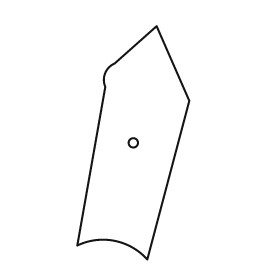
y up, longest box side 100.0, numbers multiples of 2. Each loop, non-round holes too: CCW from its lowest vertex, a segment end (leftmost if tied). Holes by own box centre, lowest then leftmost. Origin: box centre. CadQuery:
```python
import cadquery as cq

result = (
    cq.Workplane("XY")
    .moveTo(6.0, -50.0)
    .lineTo(24.0, 18.0)
    .lineTo(10.0, 50.0)
    .lineTo(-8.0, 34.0)
    .threePointArc((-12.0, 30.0), (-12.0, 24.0))
    .lineTo(-24.0, -44.0)
    .threePointArc((-8.0, -42.0), (6.0, -50.0))
    .close()
    .moveTo(0.0, 0.0)
    .circle(2.0)
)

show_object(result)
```